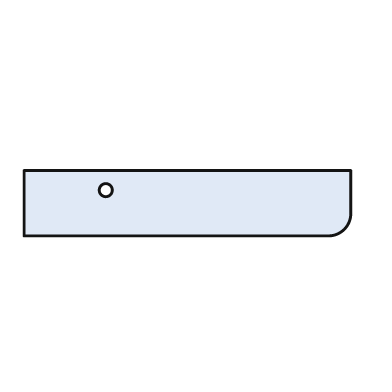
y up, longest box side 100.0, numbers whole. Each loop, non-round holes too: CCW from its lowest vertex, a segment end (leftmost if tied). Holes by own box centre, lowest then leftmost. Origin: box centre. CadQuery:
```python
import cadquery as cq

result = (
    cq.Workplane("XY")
    .moveTo(-50.0, -10.0)
    .lineTo(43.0, -10.0)
    .threePointArc((48.0, -8.0), (50.0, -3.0))
    .lineTo(50.0, 10.0)
    .lineTo(-50.0, 10.0)
    .close()
    .moveTo(-25.0, 4.0)
    .circle(2.0)
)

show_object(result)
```